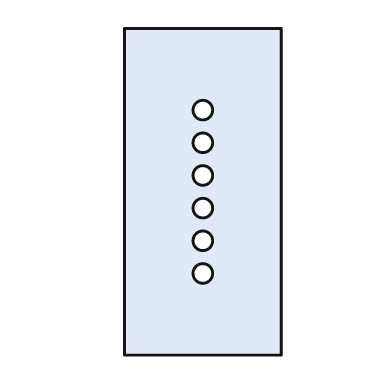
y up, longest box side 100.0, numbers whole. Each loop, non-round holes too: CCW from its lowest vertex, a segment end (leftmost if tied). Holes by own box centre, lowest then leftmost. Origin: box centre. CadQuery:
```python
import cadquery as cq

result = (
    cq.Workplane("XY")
    .moveTo(-24.0, -50.0)
    .lineTo(24.0, -50.0)
    .lineTo(24.0, 50.0)
    .lineTo(-24.0, 50.0)
    .close()
    .moveTo(0.0, -25.0)
    .circle(3.0)
    .moveTo(0.0, -15.0)
    .circle(3.0)
    .moveTo(0.0, -5.0)
    .circle(3.0)
    .moveTo(0.0, 5.0)
    .circle(3.0)
    .moveTo(0.0, 15.0)
    .circle(3.0)
    .moveTo(0.0, 25.0)
    .circle(3.0)
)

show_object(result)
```